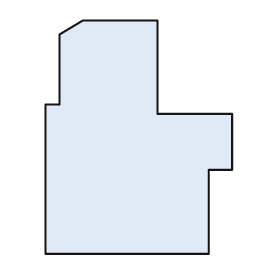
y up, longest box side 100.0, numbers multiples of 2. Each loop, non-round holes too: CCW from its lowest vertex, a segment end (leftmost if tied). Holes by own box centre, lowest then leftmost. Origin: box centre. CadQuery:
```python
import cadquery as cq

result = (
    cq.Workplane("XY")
    .moveTo(-40.0, -50.0)
    .lineTo(30.0, -50.0)
    .lineTo(30.0, -14.0)
    .lineTo(40.0, -14.0)
    .lineTo(40.0, 10.0)
    .lineTo(8.0, 10.0)
    .lineTo(8.0, 50.0)
    .lineTo(-24.0, 50.0)
    .lineTo(-34.0, 44.0)
    .lineTo(-34.0, 14.0)
    .lineTo(-40.0, 14.0)
    .close()
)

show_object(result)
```